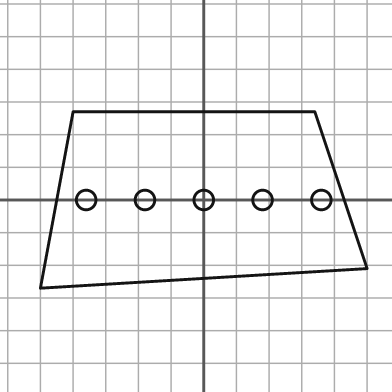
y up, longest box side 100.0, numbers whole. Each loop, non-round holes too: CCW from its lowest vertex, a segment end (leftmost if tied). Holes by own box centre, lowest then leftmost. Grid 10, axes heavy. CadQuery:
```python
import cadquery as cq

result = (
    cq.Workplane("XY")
    .moveTo(-50.0, -27.0)
    .lineTo(50.0, -21.0)
    .lineTo(34.0, 27.0)
    .lineTo(-40.0, 27.0)
    .close()
    .moveTo(-36.0, 0.0)
    .circle(3.0)
    .moveTo(-18.0, 0.0)
    .circle(3.0)
    .moveTo(0.0, 0.0)
    .circle(3.0)
    .moveTo(18.0, 0.0)
    .circle(3.0)
    .moveTo(36.0, 0.0)
    .circle(3.0)
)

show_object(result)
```